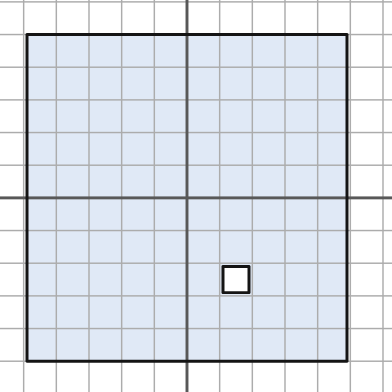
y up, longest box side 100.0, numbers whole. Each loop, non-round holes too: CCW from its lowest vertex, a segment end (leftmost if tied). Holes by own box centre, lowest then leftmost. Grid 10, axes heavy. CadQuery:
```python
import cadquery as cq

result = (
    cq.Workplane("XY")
    .moveTo(-49.0, -50.0)
    .lineTo(49.0, -50.0)
    .lineTo(49.0, 50.0)
    .lineTo(-49.0, 50.0)
    .close()
    .moveTo(11.0, -29.0)
    .lineTo(19.0, -29.0)
    .lineTo(19.0, -21.0)
    .lineTo(11.0, -21.0)
    .close()
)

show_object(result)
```